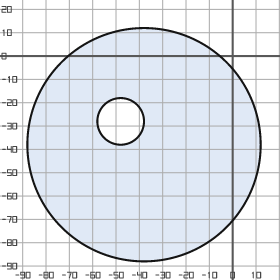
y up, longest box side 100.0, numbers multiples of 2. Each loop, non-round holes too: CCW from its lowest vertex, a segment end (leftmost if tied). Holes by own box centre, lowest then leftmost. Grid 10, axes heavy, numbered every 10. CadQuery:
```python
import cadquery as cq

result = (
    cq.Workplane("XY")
    .moveTo(-38.0, -38.0)
    .circle(50.0)
    .moveTo(-48.0, -28.0)
    .circle(10.0)
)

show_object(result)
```